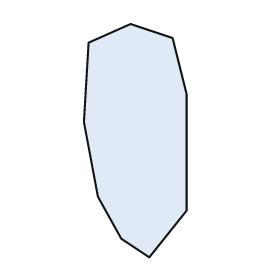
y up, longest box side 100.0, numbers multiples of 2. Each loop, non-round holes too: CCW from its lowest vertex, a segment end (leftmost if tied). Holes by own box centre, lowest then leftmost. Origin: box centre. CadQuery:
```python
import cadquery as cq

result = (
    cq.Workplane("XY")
    .moveTo(6.0, -50.0)
    .lineTo(22.0, -30.0)
    .lineTo(22.0, 20.0)
    .lineTo(16.0, 44.0)
    .lineTo(-2.0, 50.0)
    .lineTo(-20.0, 42.0)
    .lineTo(-22.0, 8.0)
    .lineTo(-16.0, -24.0)
    .lineTo(-6.0, -42.0)
    .close()
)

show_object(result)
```